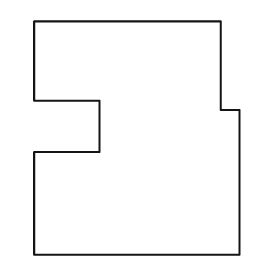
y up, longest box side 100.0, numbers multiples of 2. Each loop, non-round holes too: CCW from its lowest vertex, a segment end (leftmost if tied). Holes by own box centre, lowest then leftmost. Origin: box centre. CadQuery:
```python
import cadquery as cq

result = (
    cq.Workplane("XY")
    .moveTo(-44.0, -50.0)
    .lineTo(44.0, -50.0)
    .lineTo(44.0, 12.0)
    .lineTo(36.0, 12.0)
    .lineTo(36.0, 50.0)
    .lineTo(-44.0, 50.0)
    .lineTo(-44.0, 16.0)
    .lineTo(-16.0, 16.0)
    .lineTo(-16.0, -6.0)
    .lineTo(-44.0, -6.0)
    .close()
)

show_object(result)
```